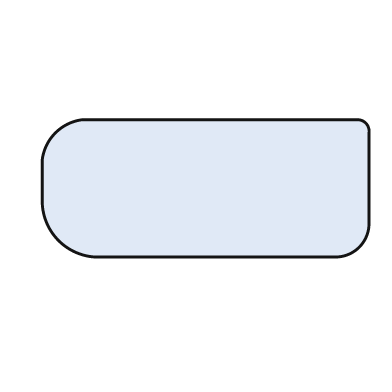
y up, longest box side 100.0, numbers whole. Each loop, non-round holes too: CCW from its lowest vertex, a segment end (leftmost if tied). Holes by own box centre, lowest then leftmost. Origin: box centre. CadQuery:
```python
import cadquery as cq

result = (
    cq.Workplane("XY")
    .moveTo(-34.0, -21.0)
    .lineTo(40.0, -21.0)
    .threePointArc((47.0, -18.0), (50.0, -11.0))
    .lineTo(50.0, 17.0)
    .threePointArc((49.0, 20.0), (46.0, 21.0))
    .lineTo(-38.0, 21.0)
    .threePointArc((-46.0, 17.0), (-50.0, 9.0))
    .lineTo(-50.0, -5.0)
    .threePointArc((-45.0, -16.0), (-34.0, -21.0))
    .close()
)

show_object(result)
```